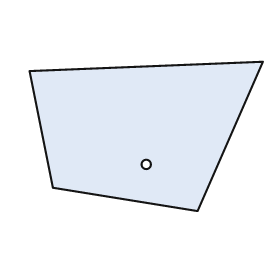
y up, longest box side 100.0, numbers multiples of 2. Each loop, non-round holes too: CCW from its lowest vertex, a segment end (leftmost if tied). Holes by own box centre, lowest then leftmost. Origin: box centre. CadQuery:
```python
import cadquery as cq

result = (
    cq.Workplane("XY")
    .moveTo(22.0, -32.0)
    .lineTo(50.0, 32.0)
    .lineTo(-50.0, 28.0)
    .lineTo(-40.0, -22.0)
    .close()
    .moveTo(0.0, -12.0)
    .circle(2.0)
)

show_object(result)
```